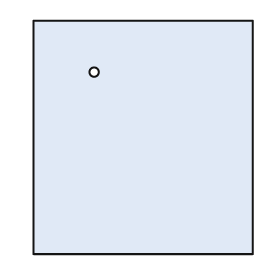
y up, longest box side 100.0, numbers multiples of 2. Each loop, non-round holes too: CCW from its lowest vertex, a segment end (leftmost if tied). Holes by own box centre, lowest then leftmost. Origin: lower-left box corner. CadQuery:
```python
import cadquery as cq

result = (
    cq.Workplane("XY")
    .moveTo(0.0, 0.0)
    .lineTo(94.0, 0.0)
    .lineTo(94.0, 100.0)
    .lineTo(0.0, 100.0)
    .close()
    .moveTo(26.0, 78.0)
    .circle(2.0)
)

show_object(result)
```